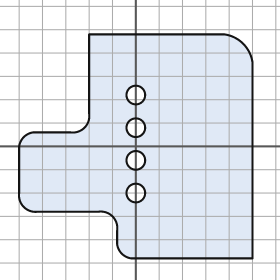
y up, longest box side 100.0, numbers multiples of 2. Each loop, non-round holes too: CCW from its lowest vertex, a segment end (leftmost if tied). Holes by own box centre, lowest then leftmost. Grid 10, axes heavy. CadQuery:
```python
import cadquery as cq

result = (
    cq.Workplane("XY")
    .moveTo(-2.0, -48.0)
    .lineTo(50.0, -48.0)
    .lineTo(50.0, 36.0)
    .threePointArc((46.0, 44.0), (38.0, 48.0))
    .lineTo(-20.0, 48.0)
    .lineTo(-20.0, 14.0)
    .threePointArc((-22.0, 8.0), (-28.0, 6.0))
    .lineTo(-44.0, 6.0)
    .threePointArc((-48.0, 4.0), (-50.0, 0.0))
    .lineTo(-50.0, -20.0)
    .threePointArc((-48.0, -26.0), (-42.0, -28.0))
    .lineTo(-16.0, -28.0)
    .threePointArc((-10.0, -30.0), (-8.0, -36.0))
    .lineTo(-8.0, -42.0)
    .threePointArc((-6.0, -46.0), (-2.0, -48.0))
    .close()
    .moveTo(0.0, -20.0)
    .circle(4.0)
    .moveTo(0.0, -6.0)
    .circle(4.0)
    .moveTo(0.0, 8.0)
    .circle(4.0)
    .moveTo(0.0, 22.0)
    .circle(4.0)
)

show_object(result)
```